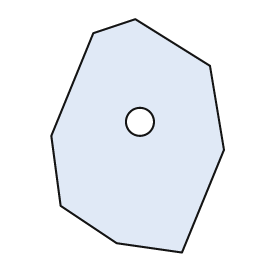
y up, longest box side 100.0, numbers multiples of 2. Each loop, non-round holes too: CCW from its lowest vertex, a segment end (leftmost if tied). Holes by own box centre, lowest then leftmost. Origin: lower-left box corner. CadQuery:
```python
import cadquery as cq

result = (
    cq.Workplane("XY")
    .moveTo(56.0, 0.0)
    .lineTo(74.0, 44.0)
    .lineTo(68.0, 80.0)
    .lineTo(36.0, 100.0)
    .lineTo(18.0, 94.0)
    .lineTo(0.0, 50.0)
    .lineTo(4.0, 20.0)
    .lineTo(28.0, 4.0)
    .close()
    .moveTo(38.0, 56.0)
    .circle(6.0)
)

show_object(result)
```